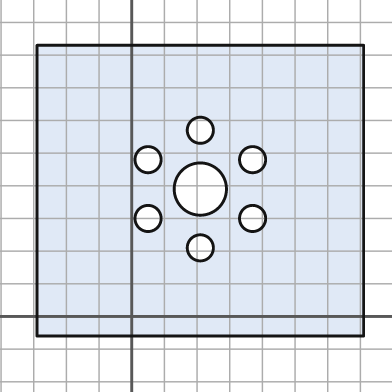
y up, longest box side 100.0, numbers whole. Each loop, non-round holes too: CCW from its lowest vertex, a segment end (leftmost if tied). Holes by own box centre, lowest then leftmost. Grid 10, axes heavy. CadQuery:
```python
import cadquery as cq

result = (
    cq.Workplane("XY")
    .moveTo(-29.0, -6.0)
    .lineTo(71.0, -6.0)
    .lineTo(71.0, 83.0)
    .lineTo(-29.0, 83.0)
    .close()
    .moveTo(21.0, 21.0)
    .circle(4.0)
    .moveTo(5.0, 30.0)
    .circle(4.0)
    .moveTo(37.0, 30.0)
    .circle(4.0)
    .moveTo(21.0, 39.0)
    .circle(8.0)
    .moveTo(5.0, 48.0)
    .circle(4.0)
    .moveTo(37.0, 48.0)
    .circle(4.0)
    .moveTo(21.0, 57.0)
    .circle(4.0)
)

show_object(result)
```